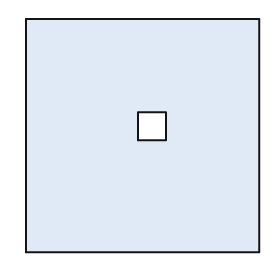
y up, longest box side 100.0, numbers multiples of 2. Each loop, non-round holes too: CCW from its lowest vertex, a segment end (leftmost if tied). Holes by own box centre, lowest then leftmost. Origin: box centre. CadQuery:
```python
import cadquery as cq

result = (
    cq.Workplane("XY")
    .moveTo(-50.0, -50.0)
    .lineTo(50.0, -50.0)
    .lineTo(50.0, 50.0)
    .lineTo(-50.0, 50.0)
    .close()
    .moveTo(-2.0, -2.0)
    .lineTo(10.0, -2.0)
    .lineTo(10.0, 10.0)
    .lineTo(-2.0, 10.0)
    .close()
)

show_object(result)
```